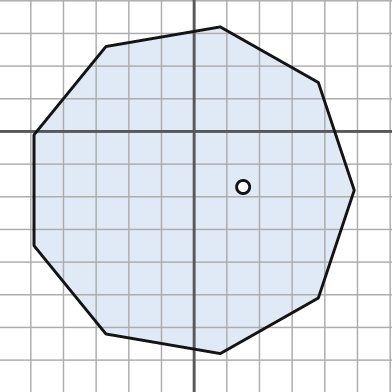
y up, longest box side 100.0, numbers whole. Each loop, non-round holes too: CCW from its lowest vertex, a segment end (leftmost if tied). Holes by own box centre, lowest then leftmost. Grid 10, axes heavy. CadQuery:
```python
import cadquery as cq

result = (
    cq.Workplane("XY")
    .moveTo(8.0, -68.0)
    .lineTo(38.0, -51.0)
    .lineTo(49.0, -18.0)
    .lineTo(38.0, 15.0)
    .lineTo(8.0, 32.0)
    .lineTo(-27.0, 26.0)
    .lineTo(-49.0, -1.0)
    .lineTo(-49.0, -35.0)
    .lineTo(-27.0, -62.0)
    .close()
    .moveTo(15.0, -17.0)
    .circle(2.0)
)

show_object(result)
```